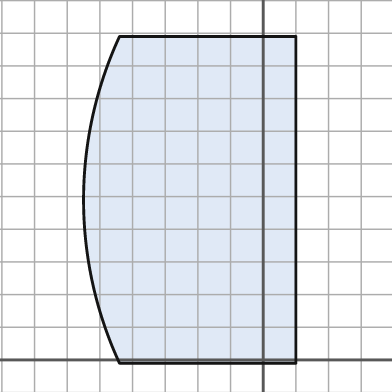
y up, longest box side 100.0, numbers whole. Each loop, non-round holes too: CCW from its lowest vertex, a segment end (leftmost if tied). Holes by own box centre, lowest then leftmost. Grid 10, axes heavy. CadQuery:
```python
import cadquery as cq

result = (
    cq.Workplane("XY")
    .moveTo(-44.0, -1.0)
    .lineTo(10.0, -1.0)
    .lineTo(10.0, 99.0)
    .lineTo(-44.0, 99.0)
    .threePointArc((-55.0, 49.0), (-44.0, -1.0))
    .close()
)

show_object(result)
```